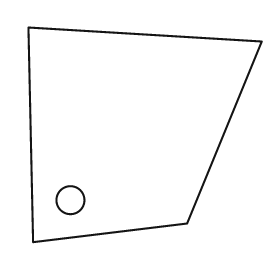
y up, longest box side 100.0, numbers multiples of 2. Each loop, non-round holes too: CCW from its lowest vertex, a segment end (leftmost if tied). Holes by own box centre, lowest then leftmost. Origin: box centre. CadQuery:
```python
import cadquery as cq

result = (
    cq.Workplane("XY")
    .moveTo(-48.0, -46.0)
    .lineTo(18.0, -38.0)
    .lineTo(50.0, 40.0)
    .lineTo(-50.0, 46.0)
    .close()
    .moveTo(-32.0, -28.0)
    .circle(6.0)
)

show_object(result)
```